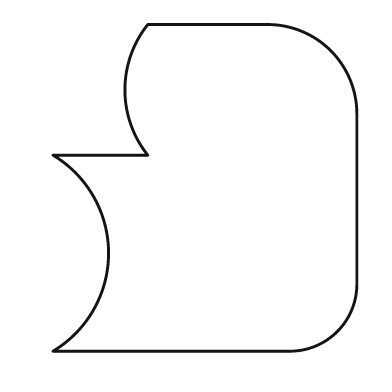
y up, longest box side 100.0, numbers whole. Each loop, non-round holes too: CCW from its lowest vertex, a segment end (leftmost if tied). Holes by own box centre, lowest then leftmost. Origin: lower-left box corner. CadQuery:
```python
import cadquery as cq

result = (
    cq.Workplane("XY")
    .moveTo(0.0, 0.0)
    .lineTo(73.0, 0.0)
    .threePointArc((87.0, 6.0), (93.0, 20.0))
    .lineTo(93.0, 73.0)
    .threePointArc((85.0, 92.0), (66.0, 100.0))
    .lineTo(29.0, 100.0)
    .threePointArc((22.0, 80.0), (29.0, 60.0))
    .lineTo(0.0, 60.0)
    .threePointArc((17.0, 30.0), (0.0, 0.0))
    .close()
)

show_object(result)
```